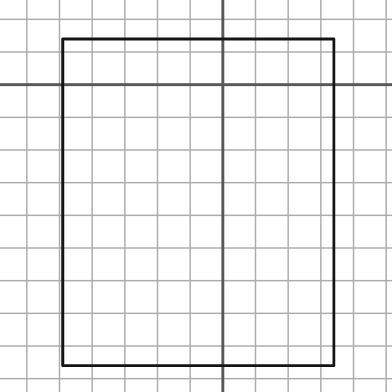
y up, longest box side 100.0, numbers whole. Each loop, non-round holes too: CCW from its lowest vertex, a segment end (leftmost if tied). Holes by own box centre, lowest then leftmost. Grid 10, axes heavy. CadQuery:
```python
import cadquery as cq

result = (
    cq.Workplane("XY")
    .moveTo(-49.0, -86.0)
    .lineTo(34.0, -86.0)
    .lineTo(34.0, 14.0)
    .lineTo(-49.0, 14.0)
    .close()
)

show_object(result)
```